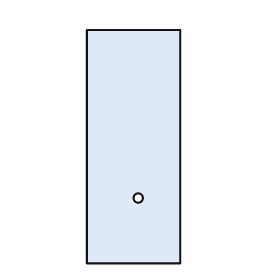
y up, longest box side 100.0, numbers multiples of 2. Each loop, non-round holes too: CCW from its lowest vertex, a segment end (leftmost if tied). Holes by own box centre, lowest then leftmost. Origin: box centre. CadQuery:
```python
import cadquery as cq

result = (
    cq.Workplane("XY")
    .moveTo(-20.0, -50.0)
    .lineTo(20.0, -50.0)
    .lineTo(20.0, 50.0)
    .lineTo(-20.0, 50.0)
    .close()
    .moveTo(2.0, -22.0)
    .circle(2.0)
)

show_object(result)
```